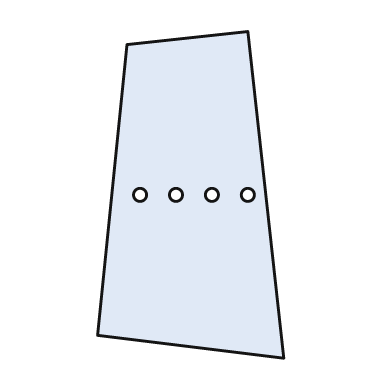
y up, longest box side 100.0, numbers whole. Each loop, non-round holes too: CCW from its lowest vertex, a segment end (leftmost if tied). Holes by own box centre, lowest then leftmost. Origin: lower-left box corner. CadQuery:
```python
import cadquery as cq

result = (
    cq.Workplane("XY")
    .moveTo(57.0, 0.0)
    .lineTo(46.0, 100.0)
    .lineTo(9.0, 96.0)
    .lineTo(0.0, 7.0)
    .close()
    .moveTo(13.0, 50.0)
    .circle(2.0)
    .moveTo(24.0, 50.0)
    .circle(2.0)
    .moveTo(35.0, 50.0)
    .circle(2.0)
    .moveTo(46.0, 50.0)
    .circle(2.0)
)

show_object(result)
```